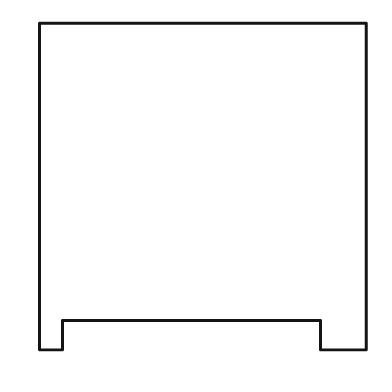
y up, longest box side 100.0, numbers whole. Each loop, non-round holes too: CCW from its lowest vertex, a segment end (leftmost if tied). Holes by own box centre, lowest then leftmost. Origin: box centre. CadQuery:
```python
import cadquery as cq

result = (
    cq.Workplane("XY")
    .moveTo(-50.0, -50.0)
    .lineTo(-43.0, -50.0)
    .lineTo(-43.0, -41.0)
    .lineTo(36.0, -41.0)
    .lineTo(36.0, -50.0)
    .lineTo(50.0, -50.0)
    .lineTo(50.0, 50.0)
    .lineTo(-50.0, 50.0)
    .close()
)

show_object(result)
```